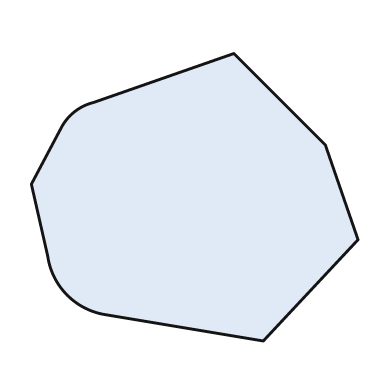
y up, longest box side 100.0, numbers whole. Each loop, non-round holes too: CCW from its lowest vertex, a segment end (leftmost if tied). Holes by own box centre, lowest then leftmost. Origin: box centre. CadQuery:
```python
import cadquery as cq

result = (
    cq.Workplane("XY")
    .moveTo(21.0, -44.0)
    .lineTo(50.0, -13.0)
    .lineTo(40.0, 16.0)
    .lineTo(12.0, 44.0)
    .lineTo(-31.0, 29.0)
    .threePointArc((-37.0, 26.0), (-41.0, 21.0))
    .lineTo(-50.0, 4.0)
    .lineTo(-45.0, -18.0)
    .threePointArc((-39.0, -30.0), (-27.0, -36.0))
    .close()
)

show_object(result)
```